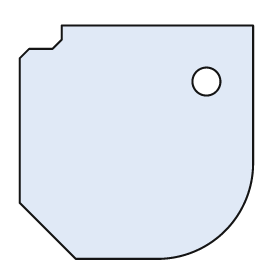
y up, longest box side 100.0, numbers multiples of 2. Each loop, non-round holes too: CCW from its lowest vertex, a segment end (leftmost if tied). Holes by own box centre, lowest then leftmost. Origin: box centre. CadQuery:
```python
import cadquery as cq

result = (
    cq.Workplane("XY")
    .moveTo(-26.0, -50.0)
    .lineTo(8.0, -50.0)
    .threePointArc((38.0, -38.0), (50.0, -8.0))
    .lineTo(50.0, 50.0)
    .lineTo(-32.0, 50.0)
    .lineTo(-32.0, 44.0)
    .lineTo(-36.0, 40.0)
    .lineTo(-46.0, 40.0)
    .lineTo(-50.0, 36.0)
    .lineTo(-50.0, -26.0)
    .close()
    .moveTo(30.0, 26.0)
    .circle(6.0)
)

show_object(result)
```